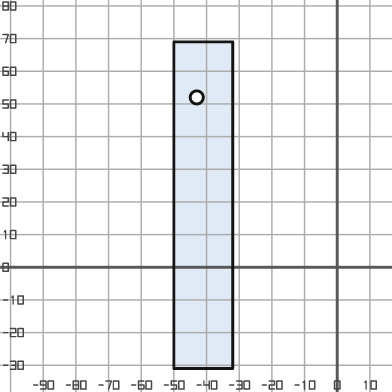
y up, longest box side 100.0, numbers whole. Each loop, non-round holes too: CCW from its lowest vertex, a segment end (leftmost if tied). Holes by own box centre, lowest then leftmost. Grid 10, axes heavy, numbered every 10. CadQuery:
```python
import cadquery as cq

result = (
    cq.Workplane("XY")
    .moveTo(-50.0, -31.0)
    .lineTo(-32.0, -31.0)
    .lineTo(-32.0, 69.0)
    .lineTo(-50.0, 69.0)
    .close()
    .moveTo(-43.0, 52.0)
    .circle(2.0)
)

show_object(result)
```